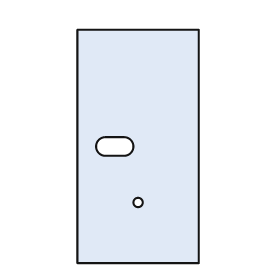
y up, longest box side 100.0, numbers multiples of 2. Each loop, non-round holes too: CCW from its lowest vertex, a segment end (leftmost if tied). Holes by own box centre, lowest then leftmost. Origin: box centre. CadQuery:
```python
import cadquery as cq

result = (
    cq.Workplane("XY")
    .moveTo(-26.0, -50.0)
    .lineTo(26.0, -50.0)
    .lineTo(26.0, 50.0)
    .lineTo(-26.0, 50.0)
    .close()
    .moveTo(0.0, -24.0)
    .circle(2.0)
    .moveTo(-14.0, -4.0)
    .lineTo(-6.0, -4.0)
    .threePointArc((-2.0, 0.0), (-6.0, 4.0))
    .lineTo(-14.0, 4.0)
    .threePointArc((-18.0, 0.0), (-14.0, -4.0))
    .close()
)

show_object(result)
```